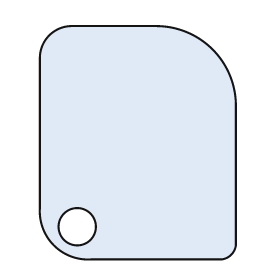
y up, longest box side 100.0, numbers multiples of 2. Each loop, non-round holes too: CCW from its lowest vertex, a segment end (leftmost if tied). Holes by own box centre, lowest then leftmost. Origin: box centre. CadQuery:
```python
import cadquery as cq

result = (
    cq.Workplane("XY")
    .moveTo(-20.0, -50.0)
    .lineTo(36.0, -50.0)
    .threePointArc((40.0, -48.0), (42.0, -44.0))
    .lineTo(42.0, 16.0)
    .threePointArc((32.0, 40.0), (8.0, 50.0))
    .lineTo(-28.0, 50.0)
    .threePointArc((-38.0, 46.0), (-42.0, 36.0))
    .lineTo(-42.0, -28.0)
    .threePointArc((-36.0, -44.0), (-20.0, -50.0))
    .close()
    .moveTo(-26.0, -36.0)
    .circle(8.0)
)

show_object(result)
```